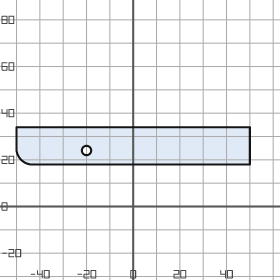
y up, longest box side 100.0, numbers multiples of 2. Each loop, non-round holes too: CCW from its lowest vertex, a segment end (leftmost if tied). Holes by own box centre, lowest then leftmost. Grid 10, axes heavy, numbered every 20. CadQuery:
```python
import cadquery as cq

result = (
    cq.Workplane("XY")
    .moveTo(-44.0, 18.0)
    .lineTo(50.0, 18.0)
    .lineTo(50.0, 34.0)
    .lineTo(-50.0, 34.0)
    .lineTo(-50.0, 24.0)
    .threePointArc((-48.0, 20.0), (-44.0, 18.0))
    .close()
    .moveTo(-20.0, 24.0)
    .circle(2.0)
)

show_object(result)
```